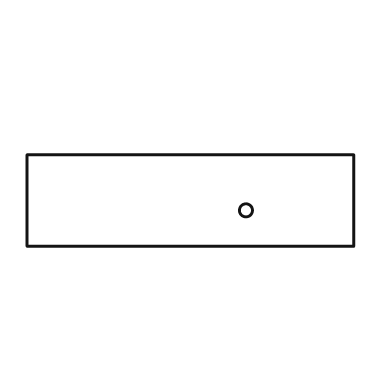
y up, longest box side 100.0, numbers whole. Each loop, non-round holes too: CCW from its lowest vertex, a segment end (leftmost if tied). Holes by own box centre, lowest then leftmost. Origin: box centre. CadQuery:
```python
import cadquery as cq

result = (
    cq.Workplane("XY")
    .moveTo(-50.0, -14.0)
    .lineTo(50.0, -14.0)
    .lineTo(50.0, 14.0)
    .lineTo(-50.0, 14.0)
    .close()
    .moveTo(17.0, -3.0)
    .circle(2.0)
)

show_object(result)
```